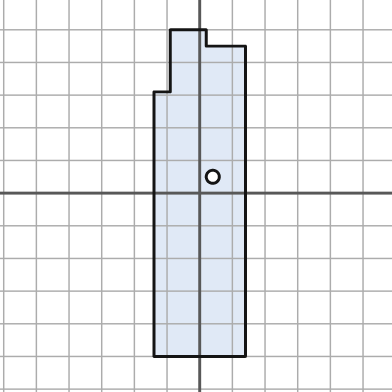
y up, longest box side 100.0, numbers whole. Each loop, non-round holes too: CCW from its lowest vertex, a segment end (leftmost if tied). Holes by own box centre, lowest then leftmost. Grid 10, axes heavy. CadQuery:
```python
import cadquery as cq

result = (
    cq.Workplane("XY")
    .moveTo(-14.0, -50.0)
    .lineTo(14.0, -50.0)
    .lineTo(14.0, 45.0)
    .lineTo(2.0, 45.0)
    .lineTo(2.0, 50.0)
    .lineTo(-9.0, 50.0)
    .lineTo(-9.0, 31.0)
    .lineTo(-14.0, 31.0)
    .close()
    .moveTo(4.0, 5.0)
    .circle(2.0)
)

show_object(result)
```